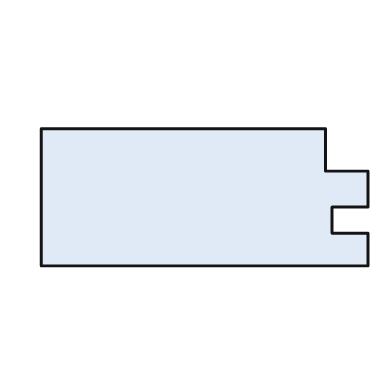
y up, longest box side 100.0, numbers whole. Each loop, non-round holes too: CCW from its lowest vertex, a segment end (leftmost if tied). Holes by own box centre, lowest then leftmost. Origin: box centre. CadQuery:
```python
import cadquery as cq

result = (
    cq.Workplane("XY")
    .moveTo(-50.0, -21.0)
    .lineTo(50.0, -21.0)
    .lineTo(50.0, -11.0)
    .lineTo(39.0, -11.0)
    .lineTo(39.0, -3.0)
    .lineTo(50.0, -3.0)
    .lineTo(50.0, 8.0)
    .lineTo(37.0, 8.0)
    .lineTo(37.0, 21.0)
    .lineTo(-50.0, 21.0)
    .close()
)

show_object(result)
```